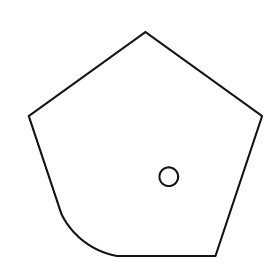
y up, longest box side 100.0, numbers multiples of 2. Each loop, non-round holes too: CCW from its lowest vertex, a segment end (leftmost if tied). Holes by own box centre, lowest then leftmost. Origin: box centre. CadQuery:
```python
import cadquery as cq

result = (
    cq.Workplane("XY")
    .moveTo(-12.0, -48.0)
    .lineTo(30.0, -48.0)
    .lineTo(50.0, 12.0)
    .lineTo(0.0, 48.0)
    .lineTo(-50.0, 12.0)
    .lineTo(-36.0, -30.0)
    .threePointArc((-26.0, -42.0), (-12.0, -48.0))
    .close()
    .moveTo(10.0, -14.0)
    .circle(4.0)
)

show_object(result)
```